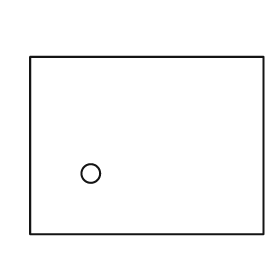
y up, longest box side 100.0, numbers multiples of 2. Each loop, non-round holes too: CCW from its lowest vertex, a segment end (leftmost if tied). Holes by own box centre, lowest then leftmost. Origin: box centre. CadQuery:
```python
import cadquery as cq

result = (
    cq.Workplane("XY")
    .moveTo(-50.0, -38.0)
    .lineTo(50.0, -38.0)
    .lineTo(50.0, 38.0)
    .lineTo(-50.0, 38.0)
    .close()
    .moveTo(-24.0, -12.0)
    .circle(4.0)
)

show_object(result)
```